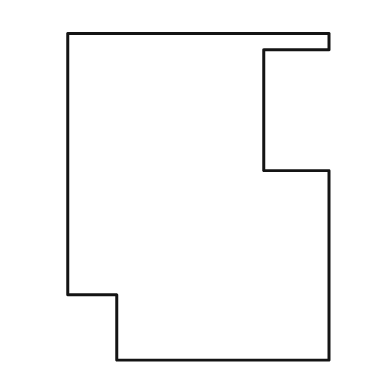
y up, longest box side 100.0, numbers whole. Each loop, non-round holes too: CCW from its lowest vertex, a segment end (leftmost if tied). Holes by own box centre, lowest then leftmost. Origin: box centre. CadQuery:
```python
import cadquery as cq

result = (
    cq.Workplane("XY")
    .moveTo(-25.0, -50.0)
    .lineTo(40.0, -50.0)
    .lineTo(40.0, 8.0)
    .lineTo(20.0, 8.0)
    .lineTo(20.0, 45.0)
    .lineTo(40.0, 45.0)
    .lineTo(40.0, 50.0)
    .lineTo(-40.0, 50.0)
    .lineTo(-40.0, -30.0)
    .lineTo(-25.0, -30.0)
    .close()
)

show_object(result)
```